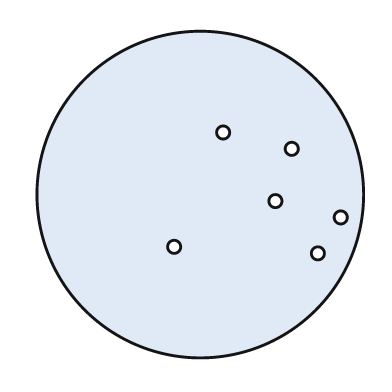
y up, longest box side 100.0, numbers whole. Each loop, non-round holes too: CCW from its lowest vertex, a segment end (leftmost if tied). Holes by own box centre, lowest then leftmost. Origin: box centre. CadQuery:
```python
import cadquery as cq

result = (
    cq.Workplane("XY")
    .moveTo(0.0, 0.0)
    .circle(50.0)
    .moveTo(36.0, -18.0)
    .circle(2.0)
    .moveTo(-8.0, -16.0)
    .circle(2.0)
    .moveTo(43.0, -7.0)
    .circle(2.0)
    .moveTo(23.0, -2.0)
    .circle(2.0)
    .moveTo(28.0, 14.0)
    .circle(2.0)
    .moveTo(7.0, 19.0)
    .circle(2.0)
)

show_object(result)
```